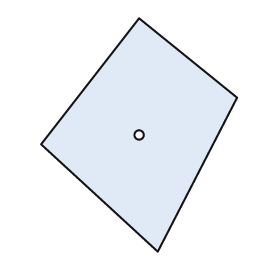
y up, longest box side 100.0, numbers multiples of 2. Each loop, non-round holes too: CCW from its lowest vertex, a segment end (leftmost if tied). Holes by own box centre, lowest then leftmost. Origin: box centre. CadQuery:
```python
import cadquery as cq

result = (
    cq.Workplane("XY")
    .moveTo(8.0, -50.0)
    .lineTo(42.0, 16.0)
    .lineTo(0.0, 50.0)
    .lineTo(-42.0, -4.0)
    .close()
    .moveTo(0.0, 0.0)
    .circle(2.0)
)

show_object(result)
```